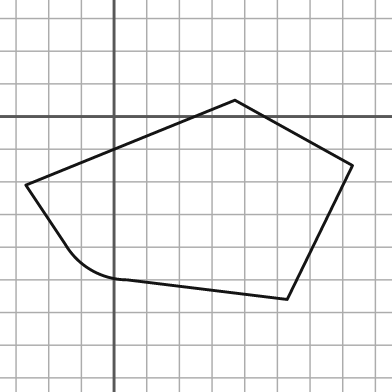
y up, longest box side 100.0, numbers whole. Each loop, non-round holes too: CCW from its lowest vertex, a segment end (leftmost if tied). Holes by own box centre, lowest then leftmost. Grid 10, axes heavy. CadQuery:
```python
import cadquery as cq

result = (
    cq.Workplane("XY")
    .moveTo(53.0, -56.0)
    .lineTo(73.0, -15.0)
    .lineTo(37.0, 5.0)
    .lineTo(-27.0, -21.0)
    .lineTo(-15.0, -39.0)
    .threePointArc((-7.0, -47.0), (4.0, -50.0))
    .close()
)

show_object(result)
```